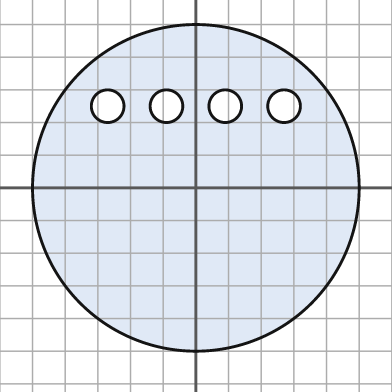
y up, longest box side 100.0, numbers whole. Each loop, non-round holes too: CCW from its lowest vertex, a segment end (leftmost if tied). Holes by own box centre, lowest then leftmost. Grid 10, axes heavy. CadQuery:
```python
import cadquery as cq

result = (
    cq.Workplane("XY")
    .moveTo(0.0, 0.0)
    .circle(50.0)
    .moveTo(-27.0, 25.0)
    .circle(5.0)
    .moveTo(-9.0, 25.0)
    .circle(5.0)
    .moveTo(9.0, 25.0)
    .circle(5.0)
    .moveTo(27.0, 25.0)
    .circle(5.0)
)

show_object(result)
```